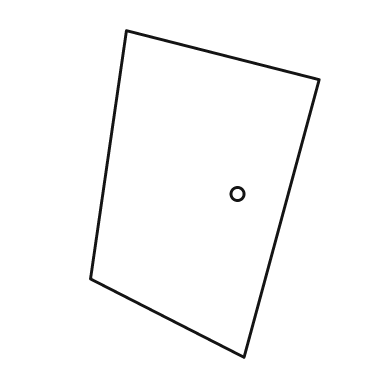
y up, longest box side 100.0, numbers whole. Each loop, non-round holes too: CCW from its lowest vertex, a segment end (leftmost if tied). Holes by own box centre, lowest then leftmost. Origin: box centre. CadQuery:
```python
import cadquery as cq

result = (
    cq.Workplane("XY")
    .moveTo(12.0, -50.0)
    .lineTo(35.0, 35.0)
    .lineTo(-24.0, 50.0)
    .lineTo(-35.0, -26.0)
    .close()
    .moveTo(10.0, 0.0)
    .circle(2.0)
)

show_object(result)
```